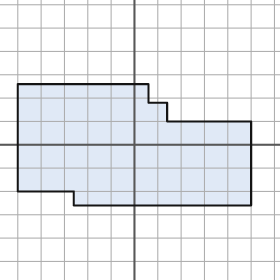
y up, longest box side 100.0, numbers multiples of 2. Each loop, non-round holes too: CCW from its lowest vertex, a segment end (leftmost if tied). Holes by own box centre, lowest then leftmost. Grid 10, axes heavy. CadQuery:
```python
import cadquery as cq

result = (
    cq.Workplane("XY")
    .moveTo(-26.0, -26.0)
    .lineTo(50.0, -26.0)
    .lineTo(50.0, 10.0)
    .lineTo(14.0, 10.0)
    .lineTo(14.0, 18.0)
    .lineTo(6.0, 18.0)
    .lineTo(6.0, 26.0)
    .lineTo(-50.0, 26.0)
    .lineTo(-50.0, -20.0)
    .lineTo(-26.0, -20.0)
    .close()
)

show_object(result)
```